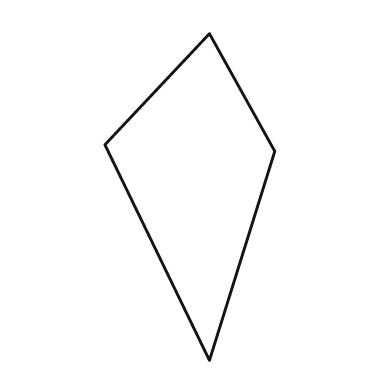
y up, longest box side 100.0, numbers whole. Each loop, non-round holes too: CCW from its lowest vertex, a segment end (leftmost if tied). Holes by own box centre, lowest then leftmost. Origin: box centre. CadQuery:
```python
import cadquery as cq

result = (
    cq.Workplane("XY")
    .moveTo(6.0, -50.0)
    .lineTo(26.0, 14.0)
    .lineTo(6.0, 50.0)
    .lineTo(-26.0, 16.0)
    .close()
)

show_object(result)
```